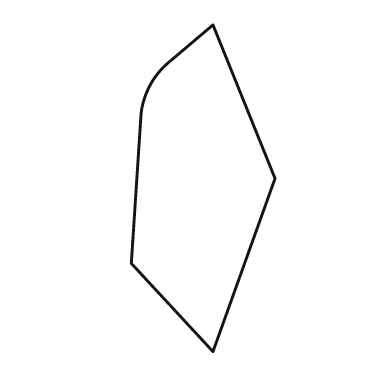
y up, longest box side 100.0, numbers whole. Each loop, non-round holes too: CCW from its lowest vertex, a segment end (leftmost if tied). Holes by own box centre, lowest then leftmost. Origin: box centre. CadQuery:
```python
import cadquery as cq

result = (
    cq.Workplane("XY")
    .moveTo(3.0, -50.0)
    .lineTo(22.0, 3.0)
    .lineTo(3.0, 50.0)
    .lineTo(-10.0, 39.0)
    .threePointArc((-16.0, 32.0), (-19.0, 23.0))
    .lineTo(-22.0, -23.0)
    .close()
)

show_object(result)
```